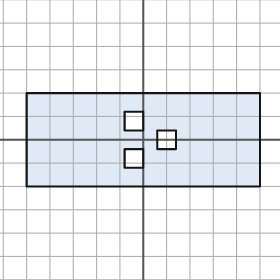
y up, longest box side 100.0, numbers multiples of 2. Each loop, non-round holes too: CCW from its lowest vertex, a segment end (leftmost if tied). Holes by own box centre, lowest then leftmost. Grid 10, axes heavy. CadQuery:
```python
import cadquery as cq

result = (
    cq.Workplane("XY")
    .moveTo(-50.0, -20.0)
    .lineTo(50.0, -20.0)
    .lineTo(50.0, 20.0)
    .lineTo(-50.0, 20.0)
    .close()
    .moveTo(-8.0, -12.0)
    .lineTo(0.0, -12.0)
    .lineTo(0.0, -4.0)
    .lineTo(-8.0, -4.0)
    .close()
    .moveTo(6.0, -4.0)
    .lineTo(14.0, -4.0)
    .lineTo(14.0, 4.0)
    .lineTo(6.0, 4.0)
    .close()
    .moveTo(-8.0, 4.0)
    .lineTo(0.0, 4.0)
    .lineTo(0.0, 12.0)
    .lineTo(-8.0, 12.0)
    .close()
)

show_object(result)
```